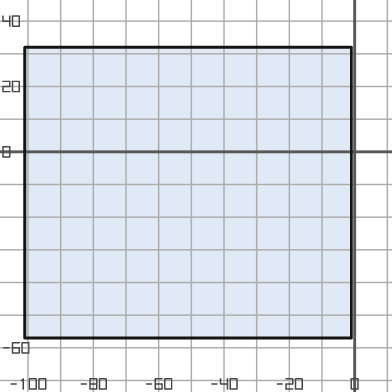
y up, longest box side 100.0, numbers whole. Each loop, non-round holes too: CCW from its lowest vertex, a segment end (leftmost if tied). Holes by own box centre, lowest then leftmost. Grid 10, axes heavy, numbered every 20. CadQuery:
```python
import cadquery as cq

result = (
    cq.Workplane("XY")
    .moveTo(-101.0, -57.0)
    .lineTo(-1.0, -57.0)
    .lineTo(-1.0, 32.0)
    .lineTo(-101.0, 32.0)
    .close()
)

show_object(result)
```